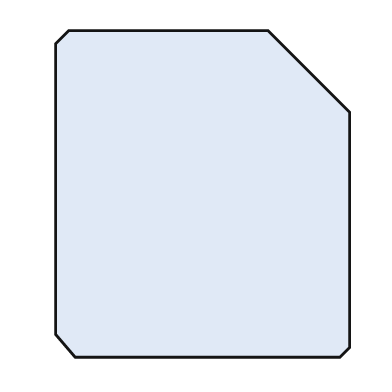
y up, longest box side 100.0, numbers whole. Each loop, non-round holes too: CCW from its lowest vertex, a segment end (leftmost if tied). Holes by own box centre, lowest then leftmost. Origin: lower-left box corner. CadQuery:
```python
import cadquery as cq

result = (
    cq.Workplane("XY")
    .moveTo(6.0, 0.0)
    .lineTo(87.0, 0.0)
    .lineTo(90.0, 3.0)
    .lineTo(90.0, 75.0)
    .lineTo(65.0, 100.0)
    .lineTo(4.0, 100.0)
    .lineTo(0.0, 96.0)
    .lineTo(0.0, 7.0)
    .close()
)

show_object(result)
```